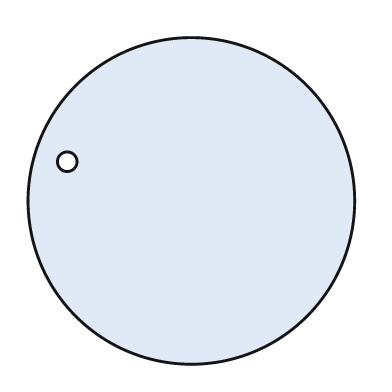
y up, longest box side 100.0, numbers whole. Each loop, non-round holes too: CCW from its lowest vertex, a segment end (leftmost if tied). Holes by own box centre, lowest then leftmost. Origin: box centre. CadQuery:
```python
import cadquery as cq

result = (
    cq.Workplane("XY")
    .moveTo(0.0, 0.0)
    .circle(50.0)
    .moveTo(-38.0, 12.0)
    .circle(3.0)
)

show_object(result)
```